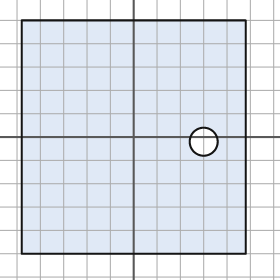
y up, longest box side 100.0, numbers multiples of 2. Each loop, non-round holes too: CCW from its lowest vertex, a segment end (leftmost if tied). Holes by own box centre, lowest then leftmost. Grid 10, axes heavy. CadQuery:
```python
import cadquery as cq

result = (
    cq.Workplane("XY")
    .moveTo(-48.0, -50.0)
    .lineTo(48.0, -50.0)
    .lineTo(48.0, 50.0)
    .lineTo(-48.0, 50.0)
    .close()
    .moveTo(30.0, -2.0)
    .circle(6.0)
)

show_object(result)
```